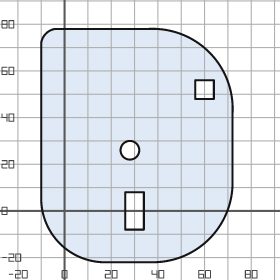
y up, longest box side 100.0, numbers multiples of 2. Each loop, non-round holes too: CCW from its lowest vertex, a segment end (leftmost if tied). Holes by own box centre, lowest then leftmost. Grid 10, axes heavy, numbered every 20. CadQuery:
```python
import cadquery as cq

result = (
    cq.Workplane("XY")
    .moveTo(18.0, -22.0)
    .lineTo(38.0, -22.0)
    .threePointArc((62.0, -12.0), (72.0, 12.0))
    .lineTo(72.0, 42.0)
    .threePointArc((62.0, 68.0), (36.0, 78.0))
    .lineTo(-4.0, 78.0)
    .threePointArc((-8.0, 76.0), (-10.0, 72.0))
    .lineTo(-10.0, 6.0)
    .threePointArc((-2.0, -14.0), (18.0, -22.0))
    .close()
    .moveTo(26.0, -8.0)
    .lineTo(34.0, -8.0)
    .lineTo(34.0, 8.0)
    .lineTo(26.0, 8.0)
    .close()
    .moveTo(28.0, 26.0)
    .circle(4.0)
    .moveTo(56.0, 48.0)
    .lineTo(64.0, 48.0)
    .lineTo(64.0, 56.0)
    .lineTo(56.0, 56.0)
    .close()
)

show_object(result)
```